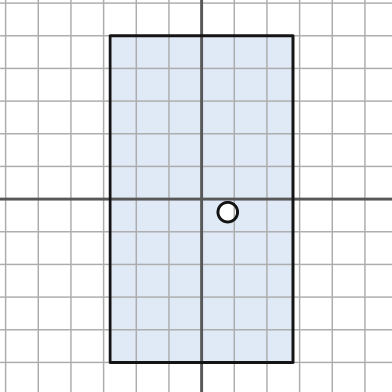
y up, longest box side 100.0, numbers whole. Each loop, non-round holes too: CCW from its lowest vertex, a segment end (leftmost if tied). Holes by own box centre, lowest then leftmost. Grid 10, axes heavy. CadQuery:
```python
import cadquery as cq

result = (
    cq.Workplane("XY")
    .moveTo(-28.0, -50.0)
    .lineTo(28.0, -50.0)
    .lineTo(28.0, 50.0)
    .lineTo(-28.0, 50.0)
    .close()
    .moveTo(8.0, -4.0)
    .circle(3.0)
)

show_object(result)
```